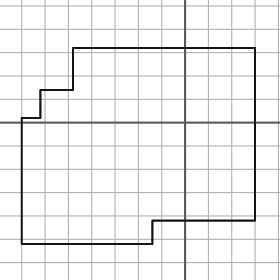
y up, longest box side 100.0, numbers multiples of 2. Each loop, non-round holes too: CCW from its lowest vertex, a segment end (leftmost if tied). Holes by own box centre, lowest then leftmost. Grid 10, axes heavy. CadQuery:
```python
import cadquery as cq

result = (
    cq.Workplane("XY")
    .moveTo(-70.0, -52.0)
    .lineTo(-14.0, -52.0)
    .lineTo(-14.0, -42.0)
    .lineTo(30.0, -42.0)
    .lineTo(30.0, 32.0)
    .lineTo(-48.0, 32.0)
    .lineTo(-48.0, 14.0)
    .lineTo(-62.0, 14.0)
    .lineTo(-62.0, 2.0)
    .lineTo(-70.0, 2.0)
    .close()
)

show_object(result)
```